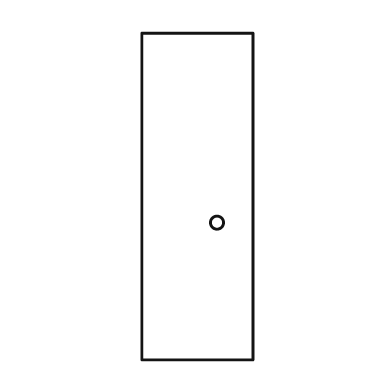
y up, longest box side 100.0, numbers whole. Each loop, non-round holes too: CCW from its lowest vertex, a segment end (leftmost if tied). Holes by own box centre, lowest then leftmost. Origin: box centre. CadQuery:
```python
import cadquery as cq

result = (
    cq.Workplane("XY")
    .moveTo(-17.0, -50.0)
    .lineTo(17.0, -50.0)
    .lineTo(17.0, 50.0)
    .lineTo(-17.0, 50.0)
    .close()
    .moveTo(6.0, -8.0)
    .circle(2.0)
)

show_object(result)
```